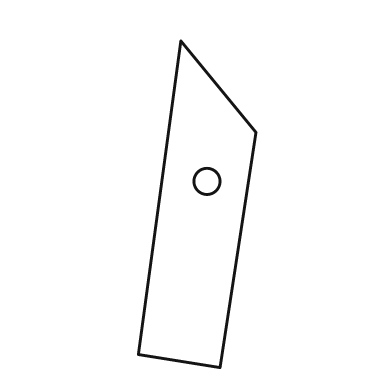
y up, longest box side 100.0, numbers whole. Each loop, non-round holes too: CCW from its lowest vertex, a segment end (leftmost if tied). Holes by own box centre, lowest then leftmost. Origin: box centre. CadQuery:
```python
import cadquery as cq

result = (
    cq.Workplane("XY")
    .moveTo(7.0, -50.0)
    .lineTo(18.0, 22.0)
    .lineTo(-5.0, 50.0)
    .lineTo(-18.0, -46.0)
    .close()
    .moveTo(3.0, 7.0)
    .circle(4.0)
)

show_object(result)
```